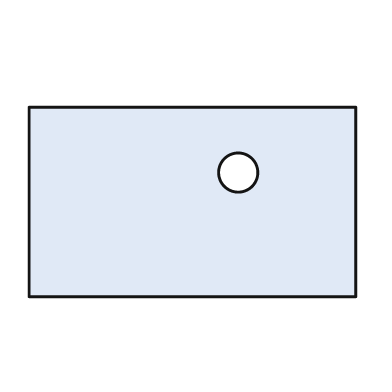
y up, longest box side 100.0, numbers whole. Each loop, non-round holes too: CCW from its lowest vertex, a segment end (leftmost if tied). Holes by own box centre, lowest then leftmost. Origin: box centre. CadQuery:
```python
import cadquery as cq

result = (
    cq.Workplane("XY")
    .moveTo(-50.0, -29.0)
    .lineTo(50.0, -29.0)
    .lineTo(50.0, 29.0)
    .lineTo(-50.0, 29.0)
    .close()
    .moveTo(14.0, 9.0)
    .circle(6.0)
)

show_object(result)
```